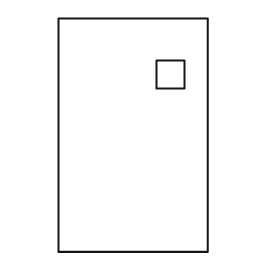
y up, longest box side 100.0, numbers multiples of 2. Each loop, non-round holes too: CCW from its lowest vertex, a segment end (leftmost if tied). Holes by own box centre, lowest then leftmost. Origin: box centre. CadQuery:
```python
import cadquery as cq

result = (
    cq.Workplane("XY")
    .moveTo(-32.0, -50.0)
    .lineTo(32.0, -50.0)
    .lineTo(32.0, 50.0)
    .lineTo(-32.0, 50.0)
    .close()
    .moveTo(10.0, 20.0)
    .lineTo(22.0, 20.0)
    .lineTo(22.0, 32.0)
    .lineTo(10.0, 32.0)
    .close()
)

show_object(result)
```